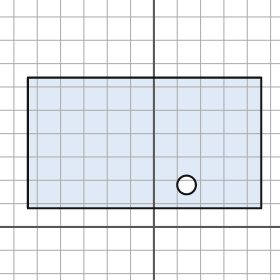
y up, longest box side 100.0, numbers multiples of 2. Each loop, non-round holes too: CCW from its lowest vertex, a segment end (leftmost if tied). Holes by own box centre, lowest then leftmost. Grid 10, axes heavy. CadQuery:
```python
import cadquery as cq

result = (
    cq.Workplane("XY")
    .moveTo(-54.0, 8.0)
    .lineTo(46.0, 8.0)
    .lineTo(46.0, 64.0)
    .lineTo(-54.0, 64.0)
    .close()
    .moveTo(14.0, 18.0)
    .circle(4.0)
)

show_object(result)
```